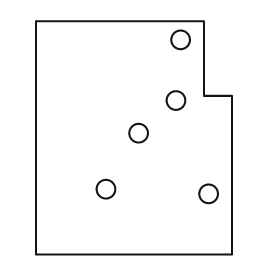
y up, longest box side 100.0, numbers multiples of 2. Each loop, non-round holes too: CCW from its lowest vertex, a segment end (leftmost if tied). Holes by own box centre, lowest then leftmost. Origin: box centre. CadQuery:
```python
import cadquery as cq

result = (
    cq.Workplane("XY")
    .moveTo(-42.0, -50.0)
    .lineTo(42.0, -50.0)
    .lineTo(42.0, 18.0)
    .lineTo(30.0, 18.0)
    .lineTo(30.0, 50.0)
    .lineTo(-42.0, 50.0)
    .close()
    .moveTo(32.0, -24.0)
    .circle(4.0)
    .moveTo(-12.0, -22.0)
    .circle(4.0)
    .moveTo(2.0, 2.0)
    .circle(4.0)
    .moveTo(18.0, 16.0)
    .circle(4.0)
    .moveTo(20.0, 42.0)
    .circle(4.0)
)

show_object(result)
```